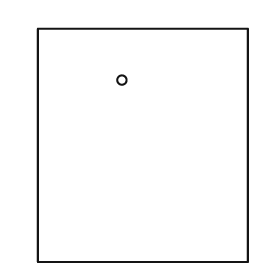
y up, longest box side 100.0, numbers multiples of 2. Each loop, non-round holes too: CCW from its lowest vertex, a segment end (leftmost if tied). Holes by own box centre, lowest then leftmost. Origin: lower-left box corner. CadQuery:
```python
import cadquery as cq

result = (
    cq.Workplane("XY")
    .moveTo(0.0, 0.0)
    .lineTo(90.0, 0.0)
    .lineTo(90.0, 100.0)
    .lineTo(0.0, 100.0)
    .close()
    .moveTo(36.0, 78.0)
    .circle(2.0)
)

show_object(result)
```